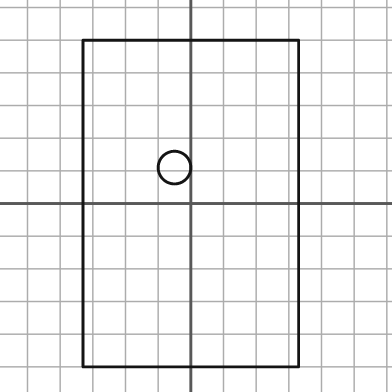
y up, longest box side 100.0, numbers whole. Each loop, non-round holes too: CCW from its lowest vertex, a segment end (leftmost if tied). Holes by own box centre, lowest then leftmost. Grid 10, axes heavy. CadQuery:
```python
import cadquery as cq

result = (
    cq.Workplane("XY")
    .moveTo(-33.0, -50.0)
    .lineTo(33.0, -50.0)
    .lineTo(33.0, 50.0)
    .lineTo(-33.0, 50.0)
    .close()
    .moveTo(-5.0, 11.0)
    .circle(5.0)
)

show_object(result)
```